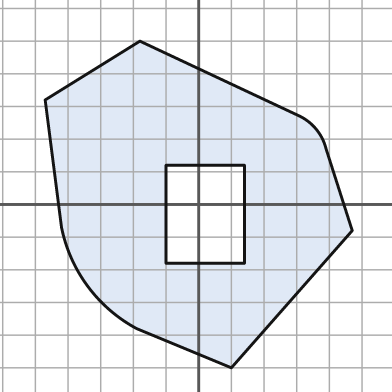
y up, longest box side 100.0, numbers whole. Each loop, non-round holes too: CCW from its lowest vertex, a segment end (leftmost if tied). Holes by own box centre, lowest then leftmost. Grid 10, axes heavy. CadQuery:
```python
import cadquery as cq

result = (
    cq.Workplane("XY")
    .moveTo(10.0, -50.0)
    .lineTo(47.0, -8.0)
    .lineTo(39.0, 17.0)
    .threePointArc((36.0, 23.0), (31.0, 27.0))
    .lineTo(-18.0, 50.0)
    .lineTo(-47.0, 32.0)
    .lineTo(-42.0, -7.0)
    .threePointArc((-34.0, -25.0), (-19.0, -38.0))
    .close()
    .moveTo(-10.0, -18.0)
    .lineTo(14.0, -18.0)
    .lineTo(14.0, 12.0)
    .lineTo(-10.0, 12.0)
    .close()
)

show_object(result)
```